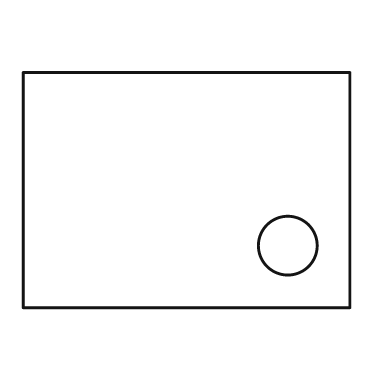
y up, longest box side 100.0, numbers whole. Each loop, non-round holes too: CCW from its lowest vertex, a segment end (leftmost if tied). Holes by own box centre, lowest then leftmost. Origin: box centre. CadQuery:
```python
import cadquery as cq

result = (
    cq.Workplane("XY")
    .moveTo(-50.0, -36.0)
    .lineTo(50.0, -36.0)
    .lineTo(50.0, 36.0)
    .lineTo(-50.0, 36.0)
    .close()
    .moveTo(31.0, -17.0)
    .circle(9.0)
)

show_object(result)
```